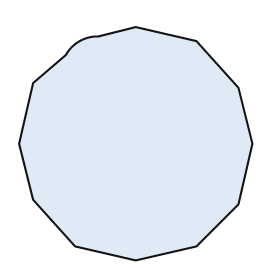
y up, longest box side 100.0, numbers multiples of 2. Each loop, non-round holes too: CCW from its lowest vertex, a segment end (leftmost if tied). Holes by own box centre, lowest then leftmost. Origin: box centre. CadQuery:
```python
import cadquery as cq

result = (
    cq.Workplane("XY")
    .moveTo(0.0, -50.0)
    .lineTo(26.0, -44.0)
    .lineTo(44.0, -26.0)
    .lineTo(50.0, 0.0)
    .lineTo(44.0, 24.0)
    .lineTo(26.0, 44.0)
    .lineTo(0.0, 50.0)
    .lineTo(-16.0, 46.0)
    .threePointArc((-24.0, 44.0), (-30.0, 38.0))
    .lineTo(-44.0, 26.0)
    .lineTo(-50.0, 0.0)
    .lineTo(-44.0, -24.0)
    .lineTo(-26.0, -44.0)
    .close()
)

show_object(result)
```